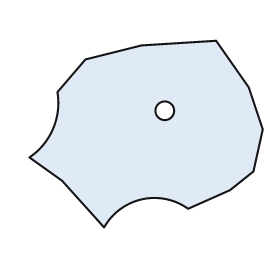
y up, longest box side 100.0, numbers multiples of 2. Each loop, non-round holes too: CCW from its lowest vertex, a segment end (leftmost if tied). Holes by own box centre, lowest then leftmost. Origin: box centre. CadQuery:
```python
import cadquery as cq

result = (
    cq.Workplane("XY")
    .moveTo(-18.0, -40.0)
    .threePointArc((-2.0, -28.0), (18.0, -32.0))
    .lineTo(36.0, -24.0)
    .lineTo(46.0, -16.0)
    .lineTo(50.0, 2.0)
    .lineTo(44.0, 20.0)
    .lineTo(30.0, 40.0)
    .lineTo(-2.0, 38.0)
    .lineTo(-26.0, 32.0)
    .lineTo(-38.0, 18.0)
    .threePointArc((-40.0, 2.0), (-50.0, -10.0))
    .lineTo(-36.0, -20.0)
    .close()
    .moveTo(8.0, 10.0)
    .circle(4.0)
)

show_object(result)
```